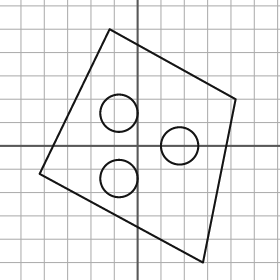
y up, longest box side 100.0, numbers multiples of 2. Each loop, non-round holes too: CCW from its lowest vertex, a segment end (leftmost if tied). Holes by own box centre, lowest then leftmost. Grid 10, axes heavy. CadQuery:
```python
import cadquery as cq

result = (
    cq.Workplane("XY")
    .moveTo(28.0, -50.0)
    .lineTo(42.0, 20.0)
    .lineTo(-12.0, 50.0)
    .lineTo(-42.0, -12.0)
    .close()
    .moveTo(-8.0, -14.0)
    .circle(8.0)
    .moveTo(18.0, 0.0)
    .circle(8.0)
    .moveTo(-8.0, 14.0)
    .circle(8.0)
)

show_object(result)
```